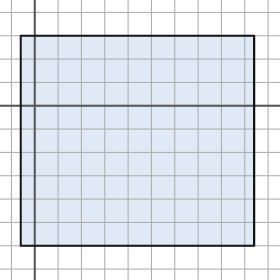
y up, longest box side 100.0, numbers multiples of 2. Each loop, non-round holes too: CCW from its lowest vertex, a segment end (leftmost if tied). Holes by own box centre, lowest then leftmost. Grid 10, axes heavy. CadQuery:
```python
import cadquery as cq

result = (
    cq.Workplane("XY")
    .moveTo(-6.0, -60.0)
    .lineTo(94.0, -60.0)
    .lineTo(94.0, 30.0)
    .lineTo(-6.0, 30.0)
    .close()
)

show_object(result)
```